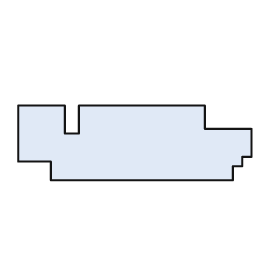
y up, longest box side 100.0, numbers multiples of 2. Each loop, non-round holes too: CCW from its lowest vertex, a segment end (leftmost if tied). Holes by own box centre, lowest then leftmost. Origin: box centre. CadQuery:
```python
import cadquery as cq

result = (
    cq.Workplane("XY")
    .moveTo(-36.0, -16.0)
    .lineTo(42.0, -16.0)
    .lineTo(42.0, -10.0)
    .lineTo(46.0, -10.0)
    .lineTo(46.0, -6.0)
    .lineTo(50.0, -6.0)
    .lineTo(50.0, 6.0)
    .lineTo(30.0, 6.0)
    .lineTo(30.0, 16.0)
    .lineTo(-24.0, 16.0)
    .lineTo(-24.0, 4.0)
    .lineTo(-30.0, 4.0)
    .lineTo(-30.0, 16.0)
    .lineTo(-50.0, 16.0)
    .lineTo(-50.0, -8.0)
    .lineTo(-36.0, -8.0)
    .close()
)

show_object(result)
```